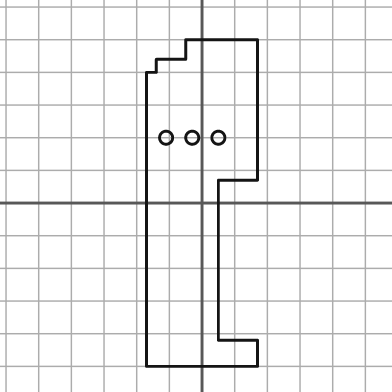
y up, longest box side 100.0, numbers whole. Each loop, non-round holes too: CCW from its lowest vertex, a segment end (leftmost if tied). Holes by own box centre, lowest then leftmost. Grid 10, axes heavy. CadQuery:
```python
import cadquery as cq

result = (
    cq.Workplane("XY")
    .moveTo(-17.0, -50.0)
    .lineTo(17.0, -50.0)
    .lineTo(17.0, -42.0)
    .lineTo(5.0, -42.0)
    .lineTo(5.0, 7.0)
    .lineTo(17.0, 7.0)
    .lineTo(17.0, 50.0)
    .lineTo(-5.0, 50.0)
    .lineTo(-5.0, 44.0)
    .lineTo(-14.0, 44.0)
    .lineTo(-14.0, 40.0)
    .lineTo(-17.0, 40.0)
    .close()
    .moveTo(-11.0, 20.0)
    .circle(2.0)
    .moveTo(-3.0, 20.0)
    .circle(2.0)
    .moveTo(5.0, 20.0)
    .circle(2.0)
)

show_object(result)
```